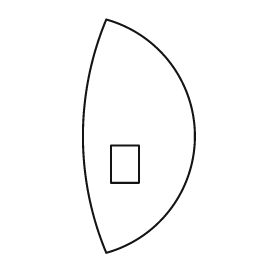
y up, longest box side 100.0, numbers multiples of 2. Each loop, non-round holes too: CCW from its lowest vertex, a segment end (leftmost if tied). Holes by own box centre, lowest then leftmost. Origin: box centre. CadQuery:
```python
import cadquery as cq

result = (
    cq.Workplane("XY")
    .moveTo(-14.0, -50.0)
    .threePointArc((24.0, 0.0), (-14.0, 50.0))
    .threePointArc((-24.0, 0.0), (-14.0, -50.0))
    .close()
    .moveTo(-12.0, -20.0)
    .lineTo(0.0, -20.0)
    .lineTo(0.0, -4.0)
    .lineTo(-12.0, -4.0)
    .close()
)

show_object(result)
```